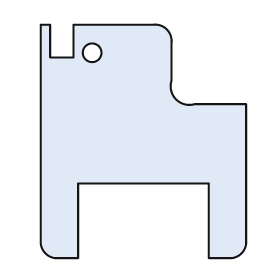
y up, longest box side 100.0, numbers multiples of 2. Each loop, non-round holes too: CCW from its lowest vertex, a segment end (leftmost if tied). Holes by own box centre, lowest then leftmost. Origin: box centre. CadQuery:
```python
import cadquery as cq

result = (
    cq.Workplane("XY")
    .moveTo(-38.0, -50.0)
    .lineTo(-28.0, -50.0)
    .lineTo(-28.0, -18.0)
    .lineTo(28.0, -18.0)
    .lineTo(28.0, -50.0)
    .lineTo(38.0, -50.0)
    .threePointArc((42.0, -48.0), (44.0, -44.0))
    .lineTo(44.0, 16.0)
    .lineTo(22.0, 16.0)
    .threePointArc((14.0, 18.0), (12.0, 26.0))
    .lineTo(12.0, 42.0)
    .threePointArc((10.0, 48.0), (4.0, 50.0))
    .lineTo(-30.0, 50.0)
    .lineTo(-30.0, 36.0)
    .lineTo(-40.0, 36.0)
    .lineTo(-40.0, 50.0)
    .lineTo(-44.0, 50.0)
    .lineTo(-44.0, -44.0)
    .threePointArc((-42.0, -48.0), (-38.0, -50.0))
    .close()
    .moveTo(-22.0, 38.0)
    .circle(4.0)
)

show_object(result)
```